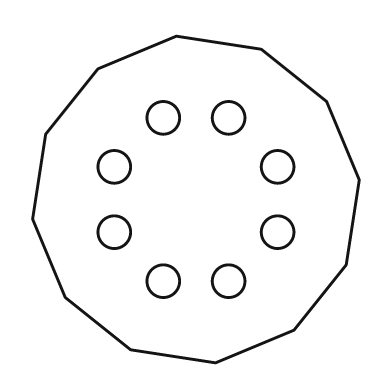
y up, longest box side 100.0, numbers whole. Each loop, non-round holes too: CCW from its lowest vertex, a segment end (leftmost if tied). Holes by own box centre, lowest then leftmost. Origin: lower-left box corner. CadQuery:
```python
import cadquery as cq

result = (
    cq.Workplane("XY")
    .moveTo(56.0, 0.0)
    .lineTo(80.0, 10.0)
    .lineTo(96.0, 30.0)
    .lineTo(100.0, 56.0)
    .lineTo(90.0, 80.0)
    .lineTo(70.0, 96.0)
    .lineTo(44.0, 100.0)
    .lineTo(20.0, 90.0)
    .lineTo(4.0, 70.0)
    .lineTo(0.0, 44.0)
    .lineTo(10.0, 20.0)
    .lineTo(30.0, 4.0)
    .close()
    .moveTo(40.0, 25.0)
    .circle(5.0)
    .moveTo(60.0, 25.0)
    .circle(5.0)
    .moveTo(25.0, 40.0)
    .circle(5.0)
    .moveTo(75.0, 40.0)
    .circle(5.0)
    .moveTo(25.0, 60.0)
    .circle(5.0)
    .moveTo(75.0, 60.0)
    .circle(5.0)
    .moveTo(40.0, 75.0)
    .circle(5.0)
    .moveTo(60.0, 75.0)
    .circle(5.0)
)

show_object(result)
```